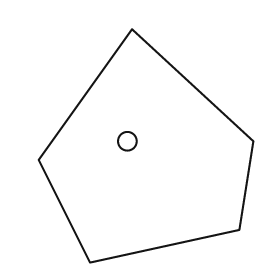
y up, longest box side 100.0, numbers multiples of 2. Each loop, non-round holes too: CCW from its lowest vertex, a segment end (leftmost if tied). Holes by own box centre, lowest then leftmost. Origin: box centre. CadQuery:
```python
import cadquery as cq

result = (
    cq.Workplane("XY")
    .moveTo(-24.0, -50.0)
    .lineTo(40.0, -36.0)
    .lineTo(46.0, 2.0)
    .lineTo(-6.0, 50.0)
    .lineTo(-46.0, -6.0)
    .close()
    .moveTo(-8.0, 2.0)
    .circle(4.0)
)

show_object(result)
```